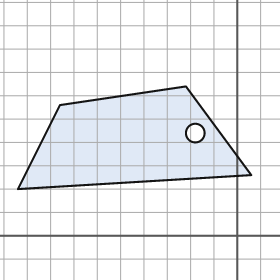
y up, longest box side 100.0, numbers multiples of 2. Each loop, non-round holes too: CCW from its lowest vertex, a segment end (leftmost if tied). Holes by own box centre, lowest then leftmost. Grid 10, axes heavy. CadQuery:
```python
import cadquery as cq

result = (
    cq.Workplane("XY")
    .moveTo(-94.0, 20.0)
    .lineTo(6.0, 26.0)
    .lineTo(-22.0, 64.0)
    .lineTo(-76.0, 56.0)
    .close()
    .moveTo(-18.0, 44.0)
    .circle(4.0)
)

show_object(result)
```